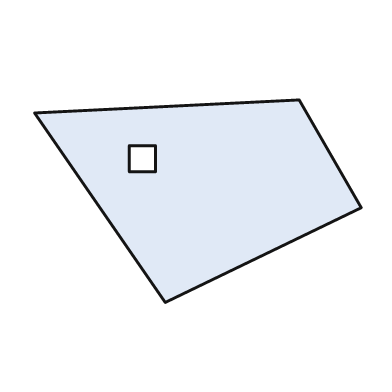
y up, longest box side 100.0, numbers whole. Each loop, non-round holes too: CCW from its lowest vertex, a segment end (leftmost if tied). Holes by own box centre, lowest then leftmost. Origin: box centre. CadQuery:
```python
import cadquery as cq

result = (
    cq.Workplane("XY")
    .moveTo(-10.0, -31.0)
    .lineTo(50.0, -2.0)
    .lineTo(31.0, 31.0)
    .lineTo(-50.0, 27.0)
    .close()
    .moveTo(-21.0, 9.0)
    .lineTo(-13.0, 9.0)
    .lineTo(-13.0, 17.0)
    .lineTo(-21.0, 17.0)
    .close()
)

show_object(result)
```